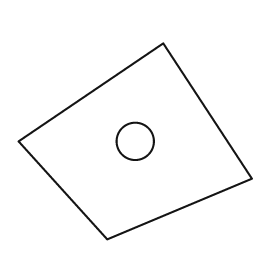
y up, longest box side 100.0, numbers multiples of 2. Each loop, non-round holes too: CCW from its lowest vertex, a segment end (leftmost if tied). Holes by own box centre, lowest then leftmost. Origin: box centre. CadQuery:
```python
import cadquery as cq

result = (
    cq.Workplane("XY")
    .moveTo(-12.0, -42.0)
    .lineTo(50.0, -16.0)
    .lineTo(12.0, 42.0)
    .lineTo(-50.0, 0.0)
    .close()
    .moveTo(0.0, 0.0)
    .circle(8.0)
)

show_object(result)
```